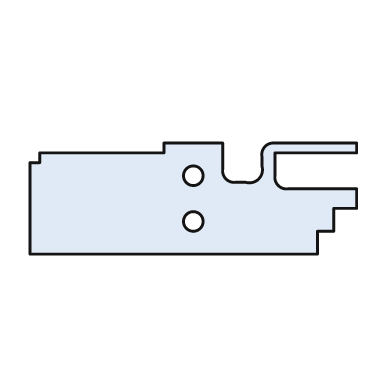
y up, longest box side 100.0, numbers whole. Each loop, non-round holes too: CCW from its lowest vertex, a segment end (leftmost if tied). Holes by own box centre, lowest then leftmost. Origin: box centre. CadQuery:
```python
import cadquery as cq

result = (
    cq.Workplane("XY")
    .moveTo(-50.0, -17.0)
    .lineTo(38.0, -17.0)
    .lineTo(38.0, -10.0)
    .lineTo(43.0, -10.0)
    .lineTo(43.0, -3.0)
    .lineTo(50.0, -3.0)
    .lineTo(50.0, 3.0)
    .lineTo(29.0, 3.0)
    .threePointArc((26.0, 4.0), (25.0, 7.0))
    .lineTo(25.0, 14.0)
    .lineTo(50.0, 14.0)
    .lineTo(50.0, 17.0)
    .lineTo(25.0, 17.0)
    .threePointArc((22.0, 16.0), (21.0, 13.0))
    .lineTo(21.0, 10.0)
    .threePointArc((20.0, 6.0), (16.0, 5.0))
    .lineTo(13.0, 5.0)
    .threePointArc((10.0, 6.0), (9.0, 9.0))
    .lineTo(9.0, 17.0)
    .lineTo(-9.0, 17.0)
    .lineTo(-9.0, 14.0)
    .lineTo(-47.0, 14.0)
    .lineTo(-47.0, 11.0)
    .lineTo(-50.0, 11.0)
    .close()
    .moveTo(0.0, -7.0)
    .circle(3.0)
    .moveTo(0.0, 7.0)
    .circle(3.0)
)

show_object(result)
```